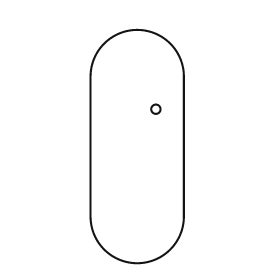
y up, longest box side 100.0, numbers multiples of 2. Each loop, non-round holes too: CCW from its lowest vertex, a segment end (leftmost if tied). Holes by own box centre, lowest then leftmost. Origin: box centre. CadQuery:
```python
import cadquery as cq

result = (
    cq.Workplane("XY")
    .moveTo(-20.0, -30.0)
    .threePointArc((0.0, -50.0), (20.0, -30.0))
    .lineTo(20.0, 30.0)
    .threePointArc((0.0, 50.0), (-20.0, 30.0))
    .close()
    .moveTo(8.0, 16.0)
    .circle(2.0)
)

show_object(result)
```